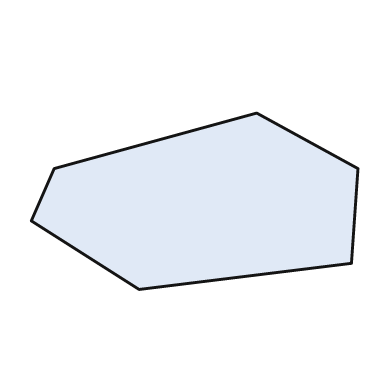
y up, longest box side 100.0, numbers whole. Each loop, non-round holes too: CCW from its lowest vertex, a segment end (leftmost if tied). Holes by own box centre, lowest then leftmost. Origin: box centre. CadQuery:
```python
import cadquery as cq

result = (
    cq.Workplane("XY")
    .moveTo(-17.0, -27.0)
    .lineTo(48.0, -19.0)
    .lineTo(50.0, 10.0)
    .lineTo(19.0, 27.0)
    .lineTo(-43.0, 10.0)
    .lineTo(-50.0, -6.0)
    .close()
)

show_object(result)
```